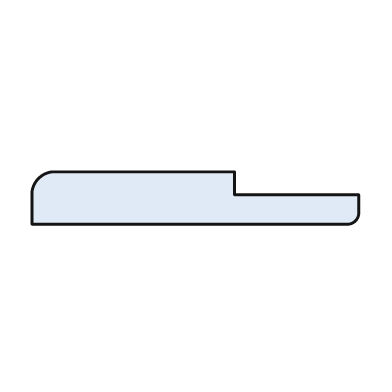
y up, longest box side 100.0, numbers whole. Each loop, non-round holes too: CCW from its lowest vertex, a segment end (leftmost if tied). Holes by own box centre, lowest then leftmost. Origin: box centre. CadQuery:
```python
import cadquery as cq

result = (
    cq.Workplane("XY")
    .moveTo(-50.0, -8.0)
    .lineTo(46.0, -8.0)
    .threePointArc((49.0, -7.0), (50.0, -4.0))
    .lineTo(50.0, 1.0)
    .lineTo(12.0, 1.0)
    .lineTo(12.0, 8.0)
    .lineTo(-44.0, 8.0)
    .threePointArc((-48.0, 6.0), (-50.0, 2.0))
    .close()
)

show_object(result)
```